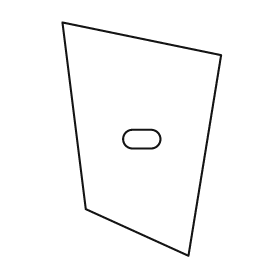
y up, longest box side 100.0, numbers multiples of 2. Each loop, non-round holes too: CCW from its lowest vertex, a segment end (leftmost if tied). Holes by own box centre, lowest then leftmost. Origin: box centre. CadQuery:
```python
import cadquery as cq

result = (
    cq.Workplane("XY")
    .moveTo(20.0, -50.0)
    .lineTo(34.0, 36.0)
    .lineTo(-34.0, 50.0)
    .lineTo(-24.0, -30.0)
    .close()
    .moveTo(-4.0, -4.0)
    .lineTo(4.0, -4.0)
    .threePointArc((8.0, 0.0), (4.0, 4.0))
    .lineTo(-4.0, 4.0)
    .threePointArc((-8.0, 0.0), (-4.0, -4.0))
    .close()
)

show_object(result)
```